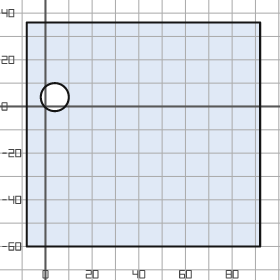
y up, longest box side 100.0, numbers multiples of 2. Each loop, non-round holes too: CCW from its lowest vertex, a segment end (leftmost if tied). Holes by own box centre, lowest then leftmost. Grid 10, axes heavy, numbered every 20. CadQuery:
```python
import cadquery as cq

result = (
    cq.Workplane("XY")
    .moveTo(-8.0, -60.0)
    .lineTo(92.0, -60.0)
    .lineTo(92.0, 36.0)
    .lineTo(-8.0, 36.0)
    .close()
    .moveTo(4.0, 4.0)
    .circle(6.0)
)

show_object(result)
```